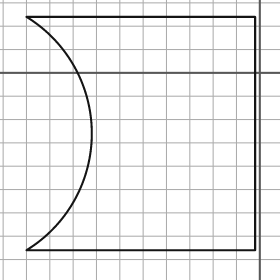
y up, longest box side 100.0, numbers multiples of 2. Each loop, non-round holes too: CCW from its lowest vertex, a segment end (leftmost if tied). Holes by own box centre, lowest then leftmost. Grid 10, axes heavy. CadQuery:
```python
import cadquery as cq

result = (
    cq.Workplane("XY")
    .moveTo(-100.0, -76.0)
    .lineTo(-2.0, -76.0)
    .lineTo(-2.0, 24.0)
    .lineTo(-100.0, 24.0)
    .threePointArc((-72.0, -26.0), (-100.0, -76.0))
    .close()
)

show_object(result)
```